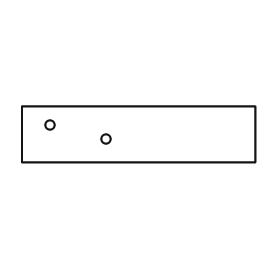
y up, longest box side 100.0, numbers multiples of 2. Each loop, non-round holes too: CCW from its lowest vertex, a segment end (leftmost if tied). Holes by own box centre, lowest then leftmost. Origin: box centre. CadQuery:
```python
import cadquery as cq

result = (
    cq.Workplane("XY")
    .moveTo(-50.0, -12.0)
    .lineTo(50.0, -12.0)
    .lineTo(50.0, 12.0)
    .lineTo(-50.0, 12.0)
    .close()
    .moveTo(-14.0, -2.0)
    .circle(2.0)
    .moveTo(-38.0, 4.0)
    .circle(2.0)
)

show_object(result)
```